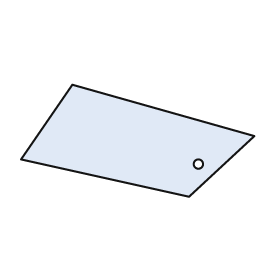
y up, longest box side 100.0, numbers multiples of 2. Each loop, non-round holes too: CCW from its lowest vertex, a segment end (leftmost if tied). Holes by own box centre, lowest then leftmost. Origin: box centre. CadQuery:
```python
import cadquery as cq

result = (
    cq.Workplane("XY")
    .moveTo(22.0, -24.0)
    .lineTo(50.0, 2.0)
    .lineTo(-28.0, 24.0)
    .lineTo(-50.0, -8.0)
    .close()
    .moveTo(26.0, -10.0)
    .circle(2.0)
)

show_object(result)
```